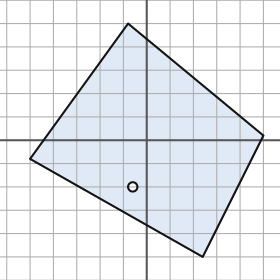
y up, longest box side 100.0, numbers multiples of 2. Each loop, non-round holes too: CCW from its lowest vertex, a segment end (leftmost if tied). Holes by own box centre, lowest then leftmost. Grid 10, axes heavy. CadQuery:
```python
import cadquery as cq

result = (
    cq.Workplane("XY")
    .moveTo(24.0, -50.0)
    .lineTo(50.0, 2.0)
    .lineTo(-8.0, 50.0)
    .lineTo(-50.0, -8.0)
    .close()
    .moveTo(-6.0, -20.0)
    .circle(2.0)
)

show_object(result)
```